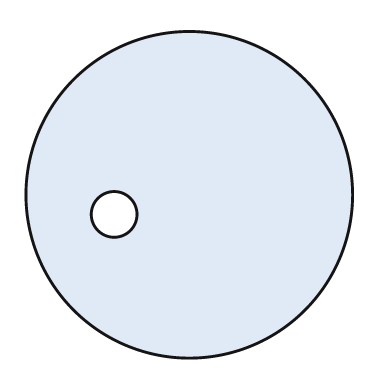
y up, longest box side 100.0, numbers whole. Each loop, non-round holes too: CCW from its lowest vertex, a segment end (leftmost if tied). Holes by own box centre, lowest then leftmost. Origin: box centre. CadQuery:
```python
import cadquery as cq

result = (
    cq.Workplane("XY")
    .moveTo(0.0, 0.0)
    .circle(50.0)
    .moveTo(-23.0, -6.0)
    .circle(7.0)
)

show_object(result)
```